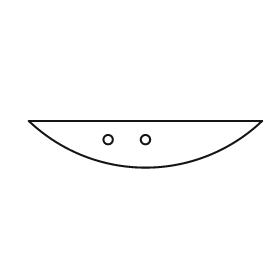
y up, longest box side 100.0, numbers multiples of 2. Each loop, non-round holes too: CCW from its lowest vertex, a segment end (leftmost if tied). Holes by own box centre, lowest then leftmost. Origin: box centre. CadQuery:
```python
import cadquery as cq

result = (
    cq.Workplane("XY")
    .moveTo(-50.0, 10.0)
    .threePointArc((0.0, -10.0), (50.0, 10.0))
    .close()
    .moveTo(-16.0, 2.0)
    .circle(2.0)
    .moveTo(0.0, 2.0)
    .circle(2.0)
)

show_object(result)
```